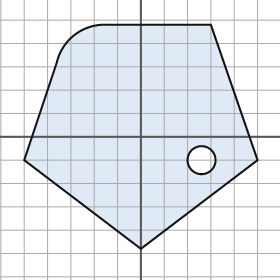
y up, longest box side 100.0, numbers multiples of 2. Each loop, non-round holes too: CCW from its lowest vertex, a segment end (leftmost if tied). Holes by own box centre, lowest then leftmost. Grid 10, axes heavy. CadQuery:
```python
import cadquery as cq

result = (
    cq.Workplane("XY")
    .moveTo(0.0, -48.0)
    .lineTo(50.0, -10.0)
    .lineTo(30.0, 48.0)
    .lineTo(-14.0, 48.0)
    .threePointArc((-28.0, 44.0), (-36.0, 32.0))
    .lineTo(-50.0, -10.0)
    .close()
    .moveTo(26.0, -10.0)
    .circle(6.0)
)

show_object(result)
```